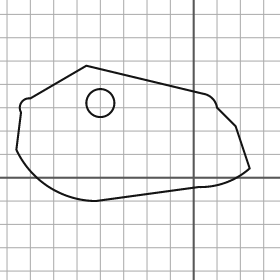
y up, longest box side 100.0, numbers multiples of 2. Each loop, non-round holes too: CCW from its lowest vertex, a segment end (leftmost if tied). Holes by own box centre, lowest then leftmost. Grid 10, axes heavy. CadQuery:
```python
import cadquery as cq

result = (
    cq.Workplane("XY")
    .moveTo(-42.0, -10.0)
    .lineTo(2.0, -4.0)
    .threePointArc((14.0, -2.0), (24.0, 4.0))
    .lineTo(18.0, 22.0)
    .lineTo(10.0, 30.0)
    .threePointArc((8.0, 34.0), (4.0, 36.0))
    .lineTo(-46.0, 48.0)
    .lineTo(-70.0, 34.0)
    .threePointArc((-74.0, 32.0), (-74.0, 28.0))
    .lineTo(-76.0, 12.0)
    .threePointArc((-62.0, -4.0), (-42.0, -10.0))
    .close()
    .moveTo(-40.0, 32.0)
    .circle(6.0)
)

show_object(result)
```